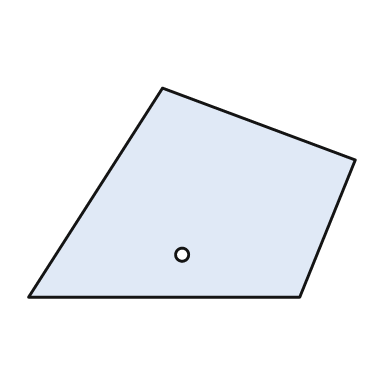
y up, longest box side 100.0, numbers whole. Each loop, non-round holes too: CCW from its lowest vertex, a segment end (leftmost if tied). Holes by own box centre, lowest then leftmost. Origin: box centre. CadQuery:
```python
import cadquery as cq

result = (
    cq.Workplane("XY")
    .moveTo(-50.0, -32.0)
    .lineTo(33.0, -32.0)
    .lineTo(50.0, 10.0)
    .lineTo(-9.0, 32.0)
    .close()
    .moveTo(-3.0, -19.0)
    .circle(2.0)
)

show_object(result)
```